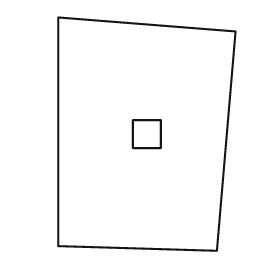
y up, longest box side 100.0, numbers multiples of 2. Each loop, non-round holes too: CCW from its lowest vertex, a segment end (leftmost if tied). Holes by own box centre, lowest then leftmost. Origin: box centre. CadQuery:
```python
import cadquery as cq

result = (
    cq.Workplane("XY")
    .moveTo(30.0, -50.0)
    .lineTo(38.0, 44.0)
    .lineTo(-38.0, 50.0)
    .lineTo(-38.0, -48.0)
    .close()
    .moveTo(-6.0, -6.0)
    .lineTo(6.0, -6.0)
    .lineTo(6.0, 6.0)
    .lineTo(-6.0, 6.0)
    .close()
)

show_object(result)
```